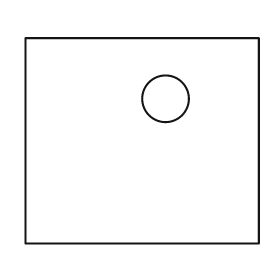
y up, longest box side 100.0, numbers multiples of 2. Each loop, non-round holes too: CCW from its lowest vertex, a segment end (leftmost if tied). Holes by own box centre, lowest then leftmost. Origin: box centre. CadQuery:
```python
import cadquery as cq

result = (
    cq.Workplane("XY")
    .moveTo(-50.0, -44.0)
    .lineTo(50.0, -44.0)
    .lineTo(50.0, 44.0)
    .lineTo(-50.0, 44.0)
    .close()
    .moveTo(10.0, 18.0)
    .circle(10.0)
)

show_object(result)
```